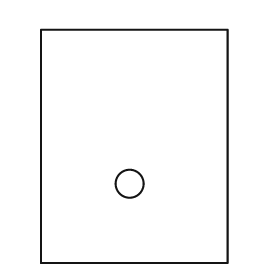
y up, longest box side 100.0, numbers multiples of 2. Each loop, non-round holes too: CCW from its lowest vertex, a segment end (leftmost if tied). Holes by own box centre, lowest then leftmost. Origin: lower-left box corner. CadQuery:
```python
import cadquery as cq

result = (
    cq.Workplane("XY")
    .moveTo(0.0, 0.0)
    .lineTo(80.0, 0.0)
    .lineTo(80.0, 100.0)
    .lineTo(0.0, 100.0)
    .close()
    .moveTo(38.0, 34.0)
    .circle(6.0)
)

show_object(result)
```